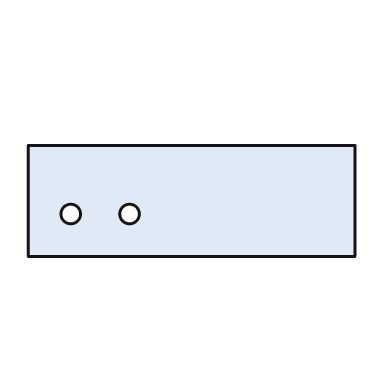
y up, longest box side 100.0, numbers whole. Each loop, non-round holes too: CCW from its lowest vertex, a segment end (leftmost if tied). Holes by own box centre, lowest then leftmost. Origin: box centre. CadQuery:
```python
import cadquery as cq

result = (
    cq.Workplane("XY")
    .moveTo(-50.0, -17.0)
    .lineTo(50.0, -17.0)
    .lineTo(50.0, 17.0)
    .lineTo(-50.0, 17.0)
    .close()
    .moveTo(-37.0, -4.0)
    .circle(3.0)
    .moveTo(-19.0, -4.0)
    .circle(3.0)
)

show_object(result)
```